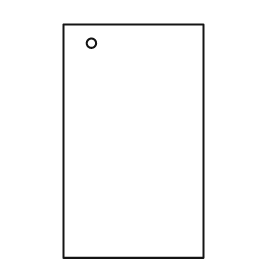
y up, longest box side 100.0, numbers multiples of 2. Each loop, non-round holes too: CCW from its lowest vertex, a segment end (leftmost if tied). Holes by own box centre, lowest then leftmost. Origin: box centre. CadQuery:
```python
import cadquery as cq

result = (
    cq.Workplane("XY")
    .moveTo(-30.0, -50.0)
    .lineTo(30.0, -50.0)
    .lineTo(30.0, 50.0)
    .lineTo(-30.0, 50.0)
    .close()
    .moveTo(-18.0, 42.0)
    .circle(2.0)
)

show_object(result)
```